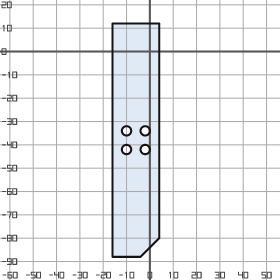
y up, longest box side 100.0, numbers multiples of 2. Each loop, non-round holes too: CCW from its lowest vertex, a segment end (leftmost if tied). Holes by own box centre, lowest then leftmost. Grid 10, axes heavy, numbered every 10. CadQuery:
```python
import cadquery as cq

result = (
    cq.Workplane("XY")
    .moveTo(-16.0, -88.0)
    .lineTo(-4.0, -88.0)
    .lineTo(4.0, -80.0)
    .lineTo(4.0, 12.0)
    .lineTo(-16.0, 12.0)
    .close()
    .moveTo(-10.0, -42.0)
    .circle(2.0)
    .moveTo(-2.0, -42.0)
    .circle(2.0)
    .moveTo(-10.0, -34.0)
    .circle(2.0)
    .moveTo(-2.0, -34.0)
    .circle(2.0)
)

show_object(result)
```